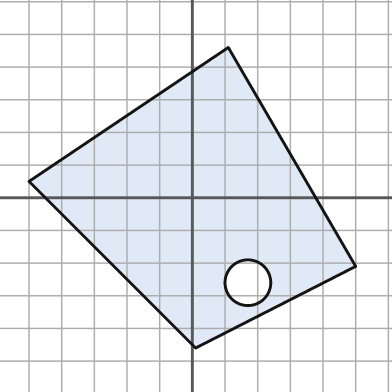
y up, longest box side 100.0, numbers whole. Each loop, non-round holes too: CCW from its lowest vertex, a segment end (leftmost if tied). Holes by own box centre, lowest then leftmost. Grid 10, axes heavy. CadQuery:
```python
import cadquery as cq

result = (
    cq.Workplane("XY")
    .moveTo(1.0, -46.0)
    .lineTo(50.0, -21.0)
    .lineTo(11.0, 46.0)
    .lineTo(-50.0, 5.0)
    .close()
    .moveTo(17.0, -26.0)
    .circle(7.0)
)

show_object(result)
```